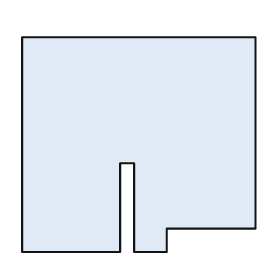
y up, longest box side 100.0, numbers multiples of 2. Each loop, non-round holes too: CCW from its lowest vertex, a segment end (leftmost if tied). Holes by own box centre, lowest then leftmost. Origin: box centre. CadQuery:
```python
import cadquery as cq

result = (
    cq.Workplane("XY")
    .moveTo(-50.0, -46.0)
    .lineTo(-8.0, -46.0)
    .lineTo(-8.0, -8.0)
    .lineTo(-2.0, -8.0)
    .lineTo(-2.0, -46.0)
    .lineTo(12.0, -46.0)
    .lineTo(12.0, -36.0)
    .lineTo(50.0, -36.0)
    .lineTo(50.0, 46.0)
    .lineTo(-50.0, 46.0)
    .close()
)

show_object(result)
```